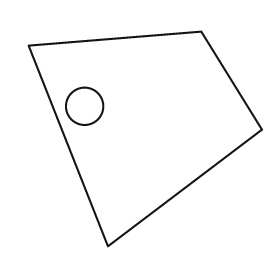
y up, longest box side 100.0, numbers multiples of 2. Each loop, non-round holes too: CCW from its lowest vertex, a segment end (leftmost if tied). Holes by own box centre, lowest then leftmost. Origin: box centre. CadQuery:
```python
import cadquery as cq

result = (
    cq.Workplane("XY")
    .moveTo(-16.0, -46.0)
    .lineTo(50.0, 4.0)
    .lineTo(24.0, 46.0)
    .lineTo(-50.0, 40.0)
    .close()
    .moveTo(-26.0, 14.0)
    .circle(8.0)
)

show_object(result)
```